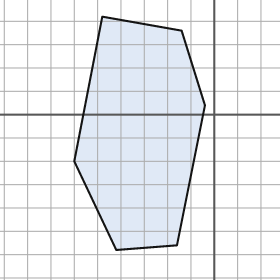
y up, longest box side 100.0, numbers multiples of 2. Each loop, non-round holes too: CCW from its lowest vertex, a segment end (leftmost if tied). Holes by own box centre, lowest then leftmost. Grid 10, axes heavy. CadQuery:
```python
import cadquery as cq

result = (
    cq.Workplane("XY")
    .moveTo(-42.0, -58.0)
    .lineTo(-16.0, -56.0)
    .lineTo(-4.0, 4.0)
    .lineTo(-14.0, 36.0)
    .lineTo(-48.0, 42.0)
    .lineTo(-60.0, -20.0)
    .close()
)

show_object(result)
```